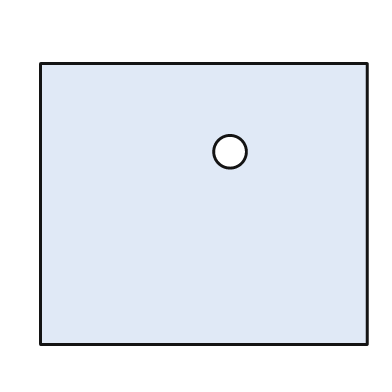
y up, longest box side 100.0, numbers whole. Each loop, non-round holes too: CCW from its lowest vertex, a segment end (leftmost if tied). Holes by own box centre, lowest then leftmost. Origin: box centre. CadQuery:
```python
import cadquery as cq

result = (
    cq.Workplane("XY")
    .moveTo(-50.0, -43.0)
    .lineTo(50.0, -43.0)
    .lineTo(50.0, 43.0)
    .lineTo(-50.0, 43.0)
    .close()
    .moveTo(8.0, 16.0)
    .circle(5.0)
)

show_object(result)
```